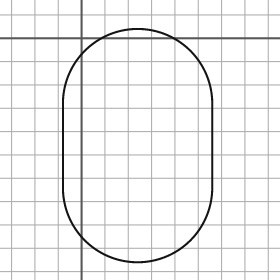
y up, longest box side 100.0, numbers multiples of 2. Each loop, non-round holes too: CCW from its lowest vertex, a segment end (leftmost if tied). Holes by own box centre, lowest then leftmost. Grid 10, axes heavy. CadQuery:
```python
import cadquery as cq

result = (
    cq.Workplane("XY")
    .moveTo(-8.0, -64.0)
    .threePointArc((24.0, -96.0), (56.0, -64.0))
    .lineTo(56.0, -28.0)
    .threePointArc((24.0, 4.0), (-8.0, -28.0))
    .close()
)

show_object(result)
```